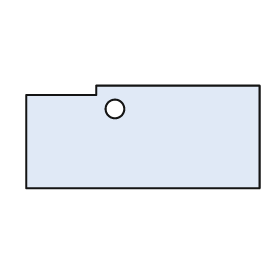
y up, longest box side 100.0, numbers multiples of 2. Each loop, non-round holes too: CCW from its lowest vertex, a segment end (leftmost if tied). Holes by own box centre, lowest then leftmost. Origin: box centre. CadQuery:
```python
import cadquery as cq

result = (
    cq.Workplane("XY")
    .moveTo(-50.0, -22.0)
    .lineTo(50.0, -22.0)
    .lineTo(50.0, 22.0)
    .lineTo(-20.0, 22.0)
    .lineTo(-20.0, 18.0)
    .lineTo(-50.0, 18.0)
    .close()
    .moveTo(-12.0, 12.0)
    .circle(4.0)
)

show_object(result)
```